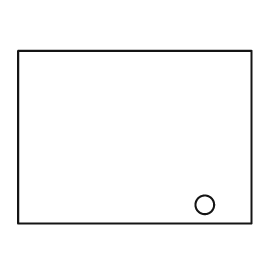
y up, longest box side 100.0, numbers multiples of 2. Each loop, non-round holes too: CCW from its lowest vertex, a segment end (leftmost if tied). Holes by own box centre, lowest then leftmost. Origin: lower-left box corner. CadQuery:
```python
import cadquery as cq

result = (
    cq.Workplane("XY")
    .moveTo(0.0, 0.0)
    .lineTo(100.0, 0.0)
    .lineTo(100.0, 74.0)
    .lineTo(0.0, 74.0)
    .close()
    .moveTo(80.0, 8.0)
    .circle(4.0)
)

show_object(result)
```